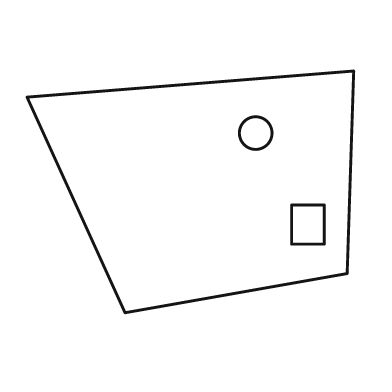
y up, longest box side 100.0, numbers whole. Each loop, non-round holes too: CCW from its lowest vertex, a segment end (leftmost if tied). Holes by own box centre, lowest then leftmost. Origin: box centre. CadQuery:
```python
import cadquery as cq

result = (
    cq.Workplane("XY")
    .moveTo(-20.0, -37.0)
    .lineTo(48.0, -25.0)
    .lineTo(50.0, 37.0)
    .lineTo(-50.0, 29.0)
    .close()
    .moveTo(31.0, -16.0)
    .lineTo(41.0, -16.0)
    .lineTo(41.0, -4.0)
    .lineTo(31.0, -4.0)
    .close()
    .moveTo(20.0, 18.0)
    .circle(5.0)
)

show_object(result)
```